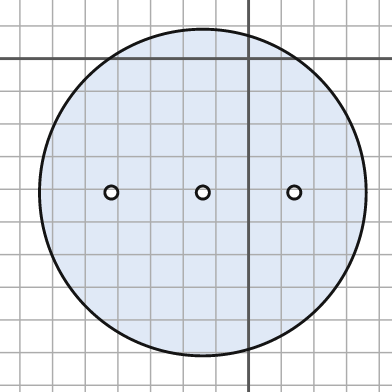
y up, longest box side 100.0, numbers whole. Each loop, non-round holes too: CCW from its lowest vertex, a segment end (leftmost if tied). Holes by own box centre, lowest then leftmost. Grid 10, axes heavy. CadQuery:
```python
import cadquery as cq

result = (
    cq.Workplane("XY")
    .moveTo(-14.0, -41.0)
    .circle(50.0)
    .moveTo(-42.0, -41.0)
    .circle(2.0)
    .moveTo(-14.0, -41.0)
    .circle(2.0)
    .moveTo(14.0, -41.0)
    .circle(2.0)
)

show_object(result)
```